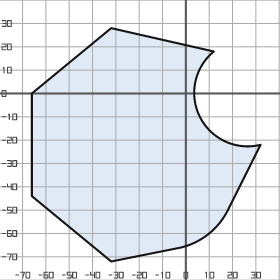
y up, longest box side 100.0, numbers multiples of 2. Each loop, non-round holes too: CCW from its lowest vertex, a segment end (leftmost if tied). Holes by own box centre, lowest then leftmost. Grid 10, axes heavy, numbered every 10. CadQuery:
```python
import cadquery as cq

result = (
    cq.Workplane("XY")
    .moveTo(-32.0, -72.0)
    .lineTo(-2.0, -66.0)
    .threePointArc((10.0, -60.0), (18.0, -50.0))
    .lineTo(32.0, -22.0)
    .threePointArc((6.0, -10.0), (12.0, 18.0))
    .lineTo(-32.0, 28.0)
    .lineTo(-66.0, 0.0)
    .lineTo(-66.0, -44.0)
    .close()
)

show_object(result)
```